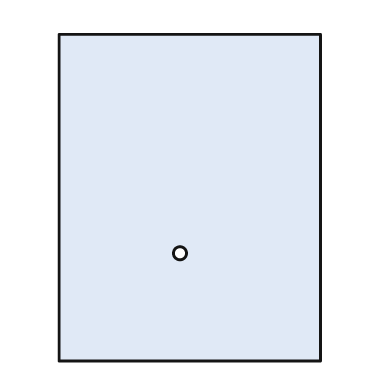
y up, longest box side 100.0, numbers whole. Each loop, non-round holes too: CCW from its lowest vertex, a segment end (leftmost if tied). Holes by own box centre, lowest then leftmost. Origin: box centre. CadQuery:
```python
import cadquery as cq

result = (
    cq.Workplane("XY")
    .moveTo(-40.0, -50.0)
    .lineTo(40.0, -50.0)
    .lineTo(40.0, 50.0)
    .lineTo(-40.0, 50.0)
    .close()
    .moveTo(-3.0, -17.0)
    .circle(2.0)
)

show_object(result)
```